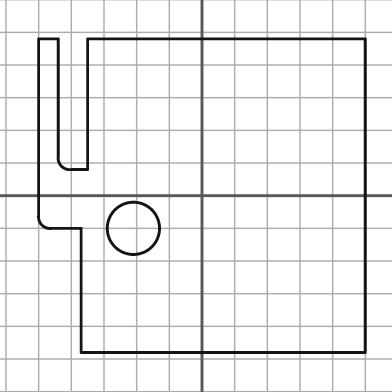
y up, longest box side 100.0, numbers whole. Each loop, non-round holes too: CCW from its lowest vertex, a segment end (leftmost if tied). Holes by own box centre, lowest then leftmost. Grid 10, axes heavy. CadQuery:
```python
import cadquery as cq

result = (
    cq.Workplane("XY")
    .moveTo(-37.0, -48.0)
    .lineTo(50.0, -48.0)
    .lineTo(50.0, 48.0)
    .lineTo(-35.0, 48.0)
    .lineTo(-35.0, 8.0)
    .lineTo(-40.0, 8.0)
    .threePointArc((-43.0, 9.0), (-44.0, 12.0))
    .lineTo(-44.0, 48.0)
    .lineTo(-50.0, 48.0)
    .lineTo(-50.0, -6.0)
    .threePointArc((-49.0, -9.0), (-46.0, -10.0))
    .lineTo(-37.0, -10.0)
    .close()
    .moveTo(-21.0, -10.0)
    .circle(8.0)
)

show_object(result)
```